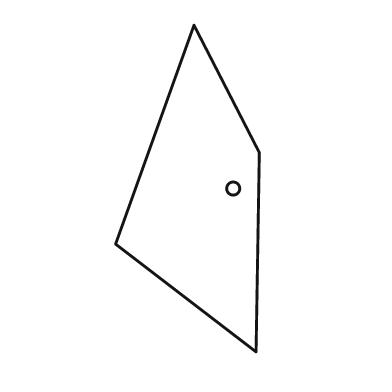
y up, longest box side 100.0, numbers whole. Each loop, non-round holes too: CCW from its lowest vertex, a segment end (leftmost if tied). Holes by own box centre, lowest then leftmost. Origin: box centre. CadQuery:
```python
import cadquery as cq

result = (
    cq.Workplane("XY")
    .moveTo(21.0, -50.0)
    .lineTo(22.0, 11.0)
    .lineTo(2.0, 50.0)
    .lineTo(-22.0, -17.0)
    .close()
    .moveTo(14.0, 0.0)
    .circle(2.0)
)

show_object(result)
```